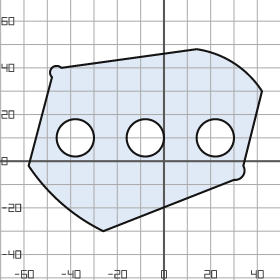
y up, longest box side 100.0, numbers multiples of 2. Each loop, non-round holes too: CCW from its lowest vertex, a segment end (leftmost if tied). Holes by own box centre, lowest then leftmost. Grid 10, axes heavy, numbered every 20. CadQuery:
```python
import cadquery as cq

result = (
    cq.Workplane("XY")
    .moveTo(-26.0, -30.0)
    .lineTo(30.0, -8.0)
    .threePointArc((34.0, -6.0), (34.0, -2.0))
    .lineTo(42.0, 30.0)
    .threePointArc((30.0, 42.0), (14.0, 48.0))
    .lineTo(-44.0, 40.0)
    .threePointArc((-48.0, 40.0), (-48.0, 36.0))
    .lineTo(-58.0, -2.0)
    .threePointArc((-44.0, -18.0), (-26.0, -30.0))
    .close()
    .moveTo(-38.0, 10.0)
    .circle(8.0)
    .moveTo(-8.0, 10.0)
    .circle(8.0)
    .moveTo(22.0, 10.0)
    .circle(8.0)
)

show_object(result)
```